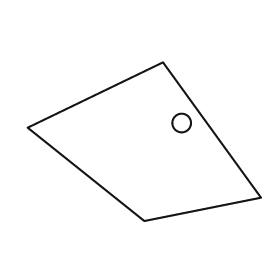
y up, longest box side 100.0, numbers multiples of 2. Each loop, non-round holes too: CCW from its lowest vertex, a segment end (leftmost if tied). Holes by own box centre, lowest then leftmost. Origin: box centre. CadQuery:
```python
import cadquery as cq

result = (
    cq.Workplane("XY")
    .moveTo(0.0, -34.0)
    .lineTo(50.0, -24.0)
    .lineTo(8.0, 34.0)
    .lineTo(-50.0, 6.0)
    .close()
    .moveTo(16.0, 8.0)
    .circle(4.0)
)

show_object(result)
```